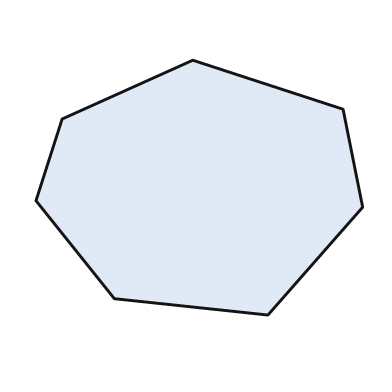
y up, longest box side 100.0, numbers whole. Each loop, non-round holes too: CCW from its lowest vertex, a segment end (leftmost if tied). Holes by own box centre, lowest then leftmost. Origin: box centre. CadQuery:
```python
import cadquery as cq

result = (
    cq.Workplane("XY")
    .moveTo(21.0, -39.0)
    .lineTo(50.0, -6.0)
    .lineTo(44.0, 24.0)
    .lineTo(-2.0, 39.0)
    .lineTo(-42.0, 21.0)
    .lineTo(-50.0, -4.0)
    .lineTo(-26.0, -34.0)
    .close()
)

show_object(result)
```